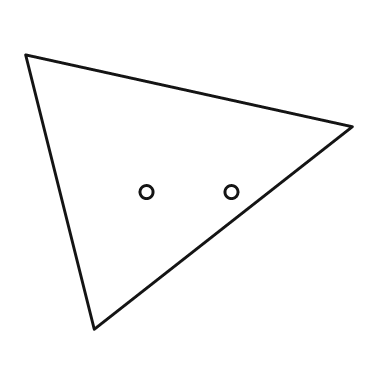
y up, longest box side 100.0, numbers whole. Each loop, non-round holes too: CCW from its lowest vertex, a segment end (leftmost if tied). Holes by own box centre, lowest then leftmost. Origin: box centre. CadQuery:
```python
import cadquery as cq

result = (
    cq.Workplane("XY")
    .moveTo(-29.0, -42.0)
    .lineTo(50.0, 20.0)
    .lineTo(-50.0, 42.0)
    .close()
    .moveTo(-13.0, 0.0)
    .circle(2.0)
    .moveTo(13.0, 0.0)
    .circle(2.0)
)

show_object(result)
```